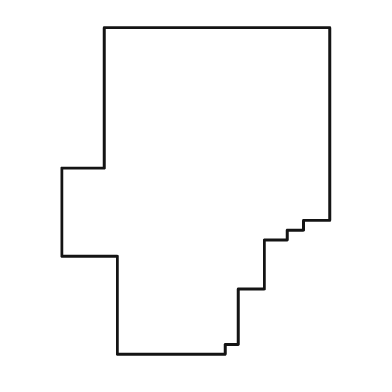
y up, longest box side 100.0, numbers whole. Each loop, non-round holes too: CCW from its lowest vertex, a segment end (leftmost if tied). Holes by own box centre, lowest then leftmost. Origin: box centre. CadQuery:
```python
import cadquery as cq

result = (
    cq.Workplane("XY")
    .moveTo(-24.0, -50.0)
    .lineTo(9.0, -50.0)
    .lineTo(9.0, -47.0)
    .lineTo(13.0, -47.0)
    .lineTo(13.0, -30.0)
    .lineTo(21.0, -30.0)
    .lineTo(21.0, -15.0)
    .lineTo(28.0, -15.0)
    .lineTo(28.0, -12.0)
    .lineTo(33.0, -12.0)
    .lineTo(33.0, -9.0)
    .lineTo(41.0, -9.0)
    .lineTo(41.0, 50.0)
    .lineTo(-28.0, 50.0)
    .lineTo(-28.0, 7.0)
    .lineTo(-41.0, 7.0)
    .lineTo(-41.0, -20.0)
    .lineTo(-24.0, -20.0)
    .close()
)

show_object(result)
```